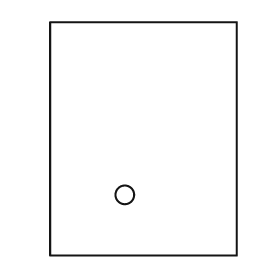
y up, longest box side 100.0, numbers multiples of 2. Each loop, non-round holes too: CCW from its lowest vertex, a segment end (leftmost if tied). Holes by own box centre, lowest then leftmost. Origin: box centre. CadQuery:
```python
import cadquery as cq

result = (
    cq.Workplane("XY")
    .moveTo(-40.0, -50.0)
    .lineTo(40.0, -50.0)
    .lineTo(40.0, 50.0)
    .lineTo(-40.0, 50.0)
    .close()
    .moveTo(-8.0, -24.0)
    .circle(4.0)
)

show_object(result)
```